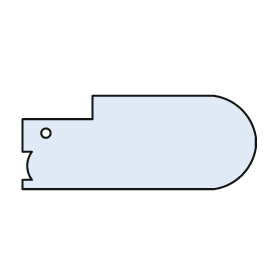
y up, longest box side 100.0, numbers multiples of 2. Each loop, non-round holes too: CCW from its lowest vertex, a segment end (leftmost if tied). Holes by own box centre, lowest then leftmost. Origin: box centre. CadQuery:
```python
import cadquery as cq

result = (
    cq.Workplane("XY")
    .moveTo(-50.0, -20.0)
    .lineTo(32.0, -20.0)
    .threePointArc((44.0, -14.0), (50.0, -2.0))
    .lineTo(50.0, 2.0)
    .threePointArc((44.0, 14.0), (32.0, 20.0))
    .lineTo(-20.0, 20.0)
    .lineTo(-20.0, 10.0)
    .lineTo(-50.0, 10.0)
    .lineTo(-50.0, -4.0)
    .lineTo(-46.0, -4.0)
    .threePointArc((-48.0, -10.0), (-46.0, -16.0))
    .lineTo(-50.0, -16.0)
    .close()
    .moveTo(-40.0, 4.0)
    .circle(2.0)
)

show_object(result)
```